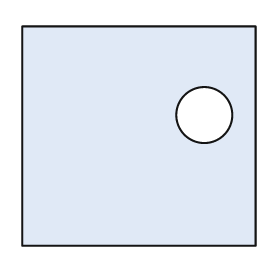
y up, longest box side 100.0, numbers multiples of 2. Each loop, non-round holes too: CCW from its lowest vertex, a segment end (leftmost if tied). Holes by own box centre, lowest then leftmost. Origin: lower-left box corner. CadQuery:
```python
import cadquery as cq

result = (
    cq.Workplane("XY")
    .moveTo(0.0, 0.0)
    .lineTo(100.0, 0.0)
    .lineTo(100.0, 94.0)
    .lineTo(0.0, 94.0)
    .close()
    .moveTo(78.0, 56.0)
    .circle(12.0)
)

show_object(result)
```